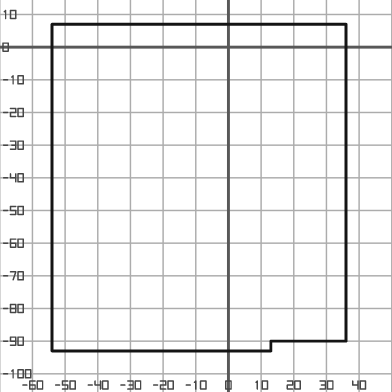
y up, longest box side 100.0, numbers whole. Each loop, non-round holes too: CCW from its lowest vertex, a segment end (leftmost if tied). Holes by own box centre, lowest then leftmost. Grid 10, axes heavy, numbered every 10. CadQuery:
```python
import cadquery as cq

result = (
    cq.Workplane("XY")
    .moveTo(-54.0, -93.0)
    .lineTo(13.0, -93.0)
    .lineTo(13.0, -90.0)
    .lineTo(36.0, -90.0)
    .lineTo(36.0, 7.0)
    .lineTo(-54.0, 7.0)
    .close()
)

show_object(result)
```